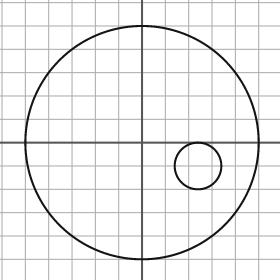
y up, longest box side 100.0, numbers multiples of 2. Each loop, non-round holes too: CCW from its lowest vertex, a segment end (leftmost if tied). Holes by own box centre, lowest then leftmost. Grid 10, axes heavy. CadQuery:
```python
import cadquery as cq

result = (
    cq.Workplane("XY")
    .moveTo(0.0, 0.0)
    .circle(50.0)
    .moveTo(24.0, -10.0)
    .circle(10.0)
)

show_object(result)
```